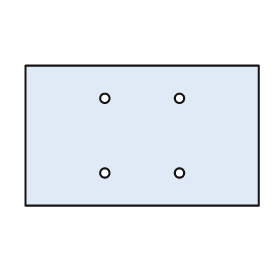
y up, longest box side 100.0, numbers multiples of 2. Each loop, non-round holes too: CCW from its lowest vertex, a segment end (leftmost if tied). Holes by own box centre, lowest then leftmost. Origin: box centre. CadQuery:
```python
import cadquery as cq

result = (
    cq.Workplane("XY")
    .moveTo(-50.0, -30.0)
    .lineTo(50.0, -30.0)
    .lineTo(50.0, 30.0)
    .lineTo(-50.0, 30.0)
    .close()
    .moveTo(-16.0, -16.0)
    .circle(2.0)
    .moveTo(16.0, -16.0)
    .circle(2.0)
    .moveTo(-16.0, 16.0)
    .circle(2.0)
    .moveTo(16.0, 16.0)
    .circle(2.0)
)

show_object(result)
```